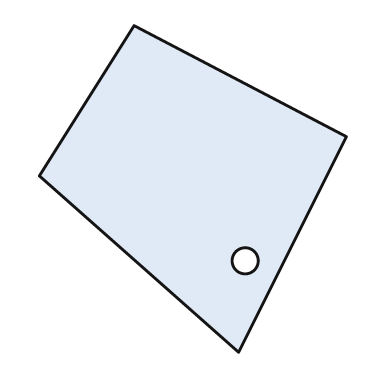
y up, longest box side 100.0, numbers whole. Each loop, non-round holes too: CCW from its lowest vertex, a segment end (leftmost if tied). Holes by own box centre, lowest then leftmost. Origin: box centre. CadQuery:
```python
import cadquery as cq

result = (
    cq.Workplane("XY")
    .moveTo(14.0, -50.0)
    .lineTo(47.0, 16.0)
    .lineTo(-18.0, 50.0)
    .lineTo(-47.0, 4.0)
    .close()
    .moveTo(16.0, -22.0)
    .circle(4.0)
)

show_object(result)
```